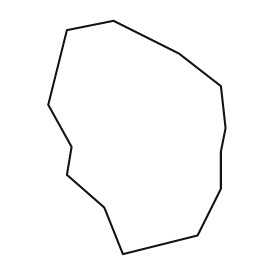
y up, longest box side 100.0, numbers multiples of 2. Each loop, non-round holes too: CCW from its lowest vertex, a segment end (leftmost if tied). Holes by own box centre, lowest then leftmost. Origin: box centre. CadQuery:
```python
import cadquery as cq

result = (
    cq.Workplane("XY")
    .moveTo(-6.0, -50.0)
    .lineTo(26.0, -42.0)
    .lineTo(36.0, -22.0)
    .lineTo(36.0, -6.0)
    .lineTo(38.0, 4.0)
    .lineTo(36.0, 22.0)
    .lineTo(18.0, 36.0)
    .lineTo(-10.0, 50.0)
    .lineTo(-30.0, 46.0)
    .lineTo(-38.0, 14.0)
    .lineTo(-28.0, -4.0)
    .lineTo(-30.0, -16.0)
    .lineTo(-14.0, -30.0)
    .close()
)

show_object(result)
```